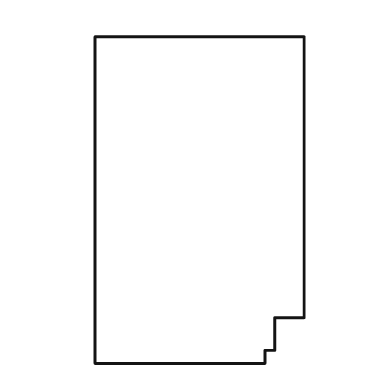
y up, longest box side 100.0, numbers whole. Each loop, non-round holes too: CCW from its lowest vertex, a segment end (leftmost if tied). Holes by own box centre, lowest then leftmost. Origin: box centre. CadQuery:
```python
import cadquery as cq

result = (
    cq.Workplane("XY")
    .moveTo(-32.0, -50.0)
    .lineTo(20.0, -50.0)
    .lineTo(20.0, -46.0)
    .lineTo(23.0, -46.0)
    .lineTo(23.0, -36.0)
    .lineTo(32.0, -36.0)
    .lineTo(32.0, 50.0)
    .lineTo(-32.0, 50.0)
    .close()
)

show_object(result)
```